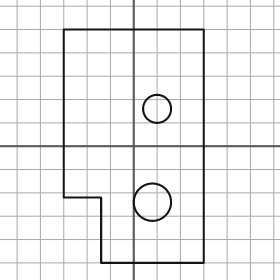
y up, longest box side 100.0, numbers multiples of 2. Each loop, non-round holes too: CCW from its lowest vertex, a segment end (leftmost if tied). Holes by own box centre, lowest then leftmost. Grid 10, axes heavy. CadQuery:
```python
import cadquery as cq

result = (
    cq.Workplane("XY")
    .moveTo(-14.0, -50.0)
    .lineTo(30.0, -50.0)
    .lineTo(30.0, 50.0)
    .lineTo(-30.0, 50.0)
    .lineTo(-30.0, -22.0)
    .lineTo(-14.0, -22.0)
    .close()
    .moveTo(8.0, -24.0)
    .circle(8.0)
    .moveTo(10.0, 16.0)
    .circle(6.0)
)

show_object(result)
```